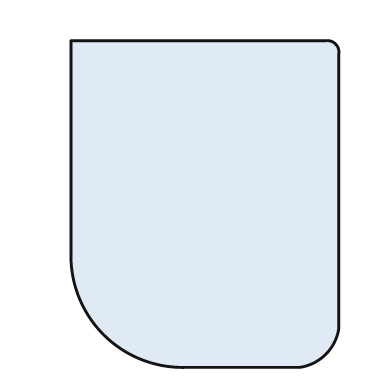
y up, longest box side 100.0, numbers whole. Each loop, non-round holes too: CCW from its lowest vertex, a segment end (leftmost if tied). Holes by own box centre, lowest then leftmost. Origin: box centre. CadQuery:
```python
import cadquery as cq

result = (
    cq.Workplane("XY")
    .moveTo(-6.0, -50.0)
    .lineTo(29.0, -50.0)
    .threePointArc((37.0, -46.0), (41.0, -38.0))
    .lineTo(41.0, 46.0)
    .threePointArc((40.0, 49.0), (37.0, 50.0))
    .lineTo(-41.0, 50.0)
    .lineTo(-41.0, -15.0)
    .threePointArc((-31.0, -40.0), (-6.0, -50.0))
    .close()
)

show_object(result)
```